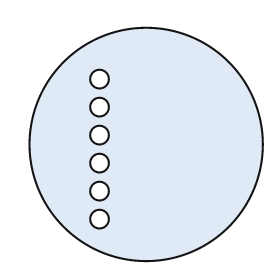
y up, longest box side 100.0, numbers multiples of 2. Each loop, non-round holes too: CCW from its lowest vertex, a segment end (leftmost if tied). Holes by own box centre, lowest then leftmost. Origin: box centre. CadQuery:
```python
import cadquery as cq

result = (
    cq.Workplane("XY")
    .moveTo(0.0, 0.0)
    .circle(50.0)
    .moveTo(-20.0, -32.0)
    .circle(4.0)
    .moveTo(-20.0, -20.0)
    .circle(4.0)
    .moveTo(-20.0, -8.0)
    .circle(4.0)
    .moveTo(-20.0, 4.0)
    .circle(4.0)
    .moveTo(-20.0, 16.0)
    .circle(4.0)
    .moveTo(-20.0, 28.0)
    .circle(4.0)
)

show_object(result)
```